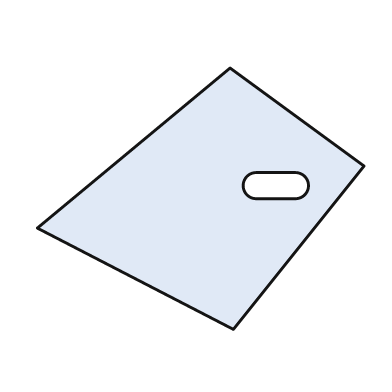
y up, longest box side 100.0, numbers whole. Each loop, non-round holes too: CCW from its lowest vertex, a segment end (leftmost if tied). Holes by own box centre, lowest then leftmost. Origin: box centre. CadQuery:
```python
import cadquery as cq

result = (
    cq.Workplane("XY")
    .moveTo(10.0, -40.0)
    .lineTo(50.0, 10.0)
    .lineTo(9.0, 40.0)
    .lineTo(-50.0, -9.0)
    .close()
    .moveTo(17.0, 0.0)
    .lineTo(29.0, 0.0)
    .threePointArc((33.0, 4.0), (29.0, 8.0))
    .lineTo(17.0, 8.0)
    .threePointArc((13.0, 4.0), (17.0, 0.0))
    .close()
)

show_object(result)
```